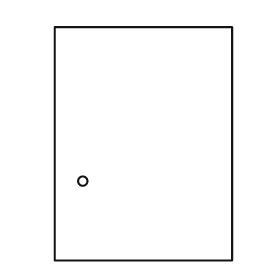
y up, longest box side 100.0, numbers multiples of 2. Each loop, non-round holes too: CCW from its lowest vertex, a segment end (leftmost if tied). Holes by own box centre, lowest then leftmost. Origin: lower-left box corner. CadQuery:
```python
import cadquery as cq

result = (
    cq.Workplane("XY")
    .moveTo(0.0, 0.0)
    .lineTo(76.0, 0.0)
    .lineTo(76.0, 100.0)
    .lineTo(0.0, 100.0)
    .close()
    .moveTo(12.0, 34.0)
    .circle(2.0)
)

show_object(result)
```